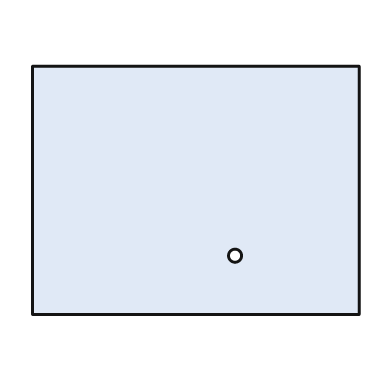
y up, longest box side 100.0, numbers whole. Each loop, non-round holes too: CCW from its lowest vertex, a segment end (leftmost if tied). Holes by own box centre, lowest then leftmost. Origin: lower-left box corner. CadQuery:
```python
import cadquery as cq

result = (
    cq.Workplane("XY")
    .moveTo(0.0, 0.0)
    .lineTo(100.0, 0.0)
    .lineTo(100.0, 76.0)
    .lineTo(0.0, 76.0)
    .close()
    .moveTo(62.0, 18.0)
    .circle(2.0)
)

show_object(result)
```